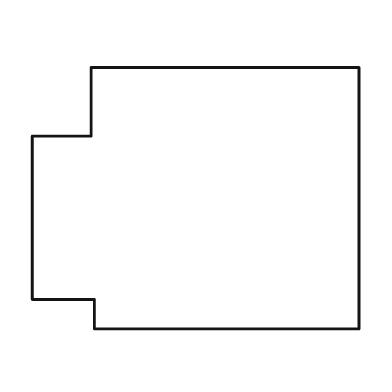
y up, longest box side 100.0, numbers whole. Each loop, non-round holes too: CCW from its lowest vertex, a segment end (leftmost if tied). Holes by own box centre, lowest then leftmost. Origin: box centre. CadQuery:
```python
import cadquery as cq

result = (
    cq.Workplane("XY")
    .moveTo(-31.0, -40.0)
    .lineTo(50.0, -40.0)
    .lineTo(50.0, 40.0)
    .lineTo(-32.0, 40.0)
    .lineTo(-32.0, 19.0)
    .lineTo(-50.0, 19.0)
    .lineTo(-50.0, -31.0)
    .lineTo(-31.0, -31.0)
    .close()
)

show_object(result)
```